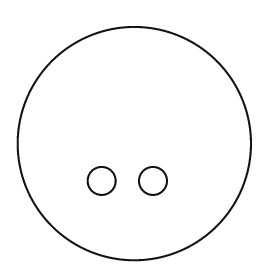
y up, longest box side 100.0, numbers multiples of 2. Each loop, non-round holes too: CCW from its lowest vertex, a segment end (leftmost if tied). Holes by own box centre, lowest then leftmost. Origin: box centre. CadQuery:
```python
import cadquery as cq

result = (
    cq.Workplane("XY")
    .moveTo(0.0, 0.0)
    .circle(50.0)
    .moveTo(-14.0, -16.0)
    .circle(6.0)
    .moveTo(8.0, -16.0)
    .circle(6.0)
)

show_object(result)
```